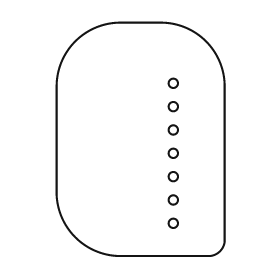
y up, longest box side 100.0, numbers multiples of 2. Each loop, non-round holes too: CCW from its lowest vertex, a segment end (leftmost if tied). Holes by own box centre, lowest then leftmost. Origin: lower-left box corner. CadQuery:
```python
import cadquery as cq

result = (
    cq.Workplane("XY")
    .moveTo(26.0, 0.0)
    .lineTo(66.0, 0.0)
    .threePointArc((70.0, 2.0), (72.0, 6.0))
    .lineTo(72.0, 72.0)
    .threePointArc((64.0, 92.0), (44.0, 100.0))
    .lineTo(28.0, 100.0)
    .threePointArc((8.0, 92.0), (0.0, 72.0))
    .lineTo(0.0, 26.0)
    .threePointArc((8.0, 8.0), (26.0, 0.0))
    .close()
    .moveTo(50.0, 14.0)
    .circle(2.0)
    .moveTo(50.0, 24.0)
    .circle(2.0)
    .moveTo(50.0, 34.0)
    .circle(2.0)
    .moveTo(50.0, 44.0)
    .circle(2.0)
    .moveTo(50.0, 54.0)
    .circle(2.0)
    .moveTo(50.0, 64.0)
    .circle(2.0)
    .moveTo(50.0, 74.0)
    .circle(2.0)
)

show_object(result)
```